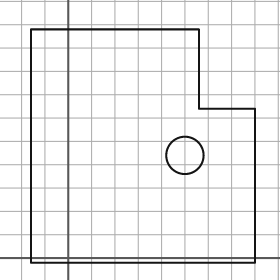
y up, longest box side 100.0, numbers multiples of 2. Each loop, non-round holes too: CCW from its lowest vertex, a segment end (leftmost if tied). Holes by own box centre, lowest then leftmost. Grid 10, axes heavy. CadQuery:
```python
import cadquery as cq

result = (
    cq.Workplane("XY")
    .moveTo(-16.0, -2.0)
    .lineTo(80.0, -2.0)
    .lineTo(80.0, 64.0)
    .lineTo(56.0, 64.0)
    .lineTo(56.0, 98.0)
    .lineTo(-16.0, 98.0)
    .close()
    .moveTo(50.0, 44.0)
    .circle(8.0)
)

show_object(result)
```